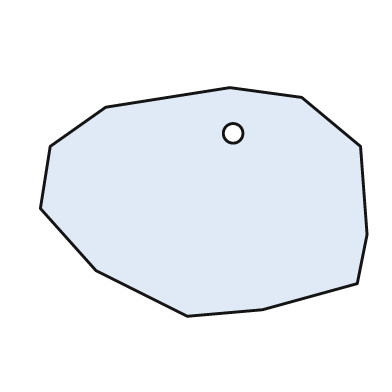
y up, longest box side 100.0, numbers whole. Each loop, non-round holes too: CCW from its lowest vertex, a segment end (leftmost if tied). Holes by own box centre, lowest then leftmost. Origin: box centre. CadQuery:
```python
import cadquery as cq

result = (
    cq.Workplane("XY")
    .moveTo(-5.0, -35.0)
    .lineTo(18.0, -33.0)
    .lineTo(47.0, -25.0)
    .lineTo(50.0, -10.0)
    .lineTo(48.0, 17.0)
    .lineTo(30.0, 32.0)
    .lineTo(8.0, 35.0)
    .lineTo(-30.0, 29.0)
    .lineTo(-47.0, 17.0)
    .lineTo(-50.0, -2.0)
    .lineTo(-33.0, -21.0)
    .close()
    .moveTo(9.0, 21.0)
    .circle(3.0)
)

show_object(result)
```